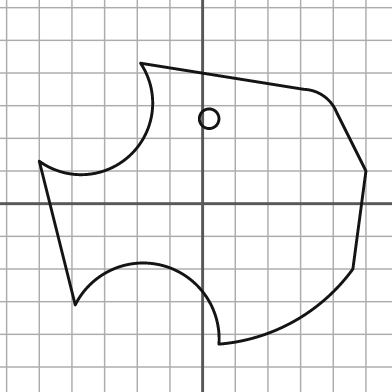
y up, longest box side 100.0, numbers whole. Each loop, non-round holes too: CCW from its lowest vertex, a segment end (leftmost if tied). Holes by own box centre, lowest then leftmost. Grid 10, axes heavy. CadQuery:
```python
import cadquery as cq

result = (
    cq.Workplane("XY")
    .moveTo(5.0, -43.0)
    .threePointArc((28.0, -36.0), (46.0, -20.0))
    .lineTo(50.0, 10.0)
    .lineTo(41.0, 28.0)
    .threePointArc((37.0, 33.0), (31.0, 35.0))
    .lineTo(-19.0, 43.0)
    .threePointArc((-22.0, 15.0), (-50.0, 13.0))
    .lineTo(-39.0, -31.0)
    .threePointArc((-12.0, -19.0), (5.0, -43.0))
    .close()
    .moveTo(2.0, 26.0)
    .circle(3.0)
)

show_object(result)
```